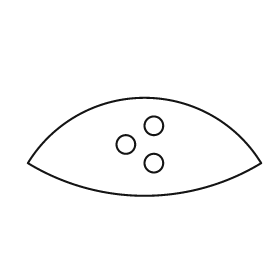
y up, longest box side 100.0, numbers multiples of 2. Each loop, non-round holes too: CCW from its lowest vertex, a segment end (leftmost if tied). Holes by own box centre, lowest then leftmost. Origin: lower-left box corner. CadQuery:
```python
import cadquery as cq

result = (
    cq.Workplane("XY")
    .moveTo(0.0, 14.0)
    .threePointArc((50.0, 0.0), (100.0, 14.0))
    .threePointArc((50.0, 42.0), (0.0, 14.0))
    .close()
    .moveTo(54.0, 14.0)
    .circle(4.0)
    .moveTo(42.0, 22.0)
    .circle(4.0)
    .moveTo(54.0, 30.0)
    .circle(4.0)
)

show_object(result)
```